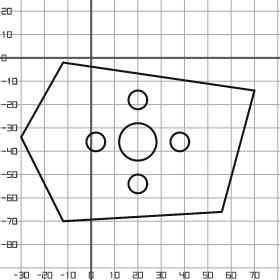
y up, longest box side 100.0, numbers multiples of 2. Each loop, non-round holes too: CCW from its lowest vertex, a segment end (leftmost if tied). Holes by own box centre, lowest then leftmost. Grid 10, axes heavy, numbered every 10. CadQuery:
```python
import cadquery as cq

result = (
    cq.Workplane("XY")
    .moveTo(-12.0, -70.0)
    .lineTo(56.0, -66.0)
    .lineTo(70.0, -14.0)
    .lineTo(-12.0, -2.0)
    .lineTo(-30.0, -34.0)
    .close()
    .moveTo(20.0, -54.0)
    .circle(4.0)
    .moveTo(2.0, -36.0)
    .circle(4.0)
    .moveTo(20.0, -36.0)
    .circle(8.0)
    .moveTo(38.0, -36.0)
    .circle(4.0)
    .moveTo(20.0, -18.0)
    .circle(4.0)
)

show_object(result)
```